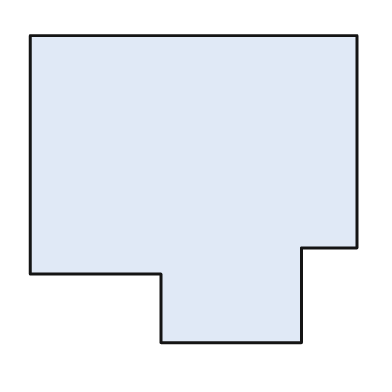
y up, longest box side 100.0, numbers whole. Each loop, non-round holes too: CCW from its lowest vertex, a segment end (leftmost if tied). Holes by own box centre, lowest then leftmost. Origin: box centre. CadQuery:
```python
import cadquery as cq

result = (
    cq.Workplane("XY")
    .moveTo(-10.0, -47.0)
    .lineTo(33.0, -47.0)
    .lineTo(33.0, -18.0)
    .lineTo(50.0, -18.0)
    .lineTo(50.0, 47.0)
    .lineTo(-50.0, 47.0)
    .lineTo(-50.0, -26.0)
    .lineTo(-10.0, -26.0)
    .close()
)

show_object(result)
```